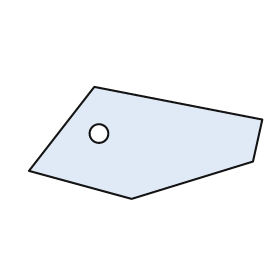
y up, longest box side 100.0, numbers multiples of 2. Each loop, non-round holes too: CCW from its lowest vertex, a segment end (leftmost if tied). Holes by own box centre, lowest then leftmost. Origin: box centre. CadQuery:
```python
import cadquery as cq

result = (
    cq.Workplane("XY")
    .moveTo(-6.0, -24.0)
    .lineTo(46.0, -8.0)
    .lineTo(50.0, 10.0)
    .lineTo(-22.0, 24.0)
    .lineTo(-50.0, -12.0)
    .close()
    .moveTo(-20.0, 4.0)
    .circle(4.0)
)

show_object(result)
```